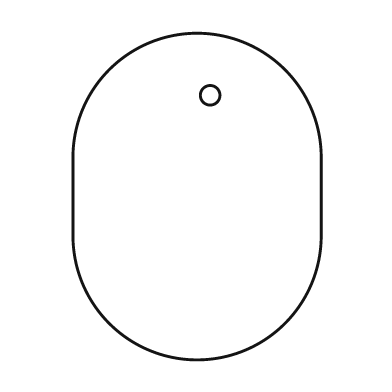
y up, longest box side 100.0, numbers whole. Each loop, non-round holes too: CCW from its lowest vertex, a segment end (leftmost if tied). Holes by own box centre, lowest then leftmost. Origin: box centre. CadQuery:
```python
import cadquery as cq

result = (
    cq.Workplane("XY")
    .moveTo(-38.0, -12.0)
    .threePointArc((0.0, -50.0), (38.0, -12.0))
    .lineTo(38.0, 12.0)
    .threePointArc((0.0, 50.0), (-38.0, 12.0))
    .close()
    .moveTo(4.0, 31.0)
    .circle(3.0)
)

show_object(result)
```